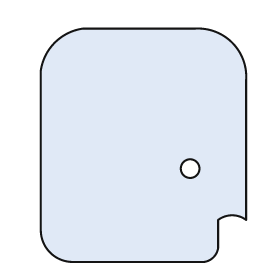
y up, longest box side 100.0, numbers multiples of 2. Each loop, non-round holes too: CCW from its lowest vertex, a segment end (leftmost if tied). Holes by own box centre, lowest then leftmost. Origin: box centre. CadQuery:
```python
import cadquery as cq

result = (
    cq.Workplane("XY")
    .moveTo(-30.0, -50.0)
    .lineTo(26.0, -50.0)
    .threePointArc((30.0, -48.0), (32.0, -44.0))
    .lineTo(32.0, -32.0)
    .threePointArc((38.0, -30.0), (44.0, -32.0))
    .lineTo(44.0, 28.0)
    .threePointArc((38.0, 44.0), (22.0, 50.0))
    .lineTo(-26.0, 50.0)
    .threePointArc((-38.0, 44.0), (-44.0, 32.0))
    .lineTo(-44.0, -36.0)
    .threePointArc((-40.0, -46.0), (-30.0, -50.0))
    .close()
    .moveTo(20.0, -10.0)
    .circle(4.0)
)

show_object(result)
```